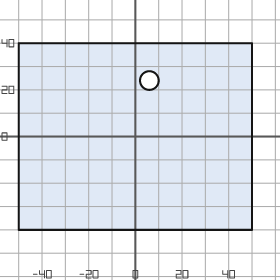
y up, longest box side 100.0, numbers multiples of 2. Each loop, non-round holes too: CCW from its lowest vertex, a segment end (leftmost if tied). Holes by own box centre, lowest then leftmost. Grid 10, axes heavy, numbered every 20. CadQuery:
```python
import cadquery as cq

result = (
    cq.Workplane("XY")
    .moveTo(-50.0, -40.0)
    .lineTo(50.0, -40.0)
    .lineTo(50.0, 40.0)
    .lineTo(-50.0, 40.0)
    .close()
    .moveTo(6.0, 24.0)
    .circle(4.0)
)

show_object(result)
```